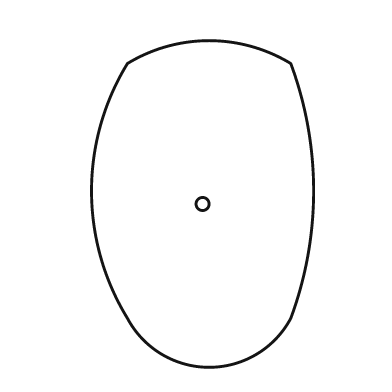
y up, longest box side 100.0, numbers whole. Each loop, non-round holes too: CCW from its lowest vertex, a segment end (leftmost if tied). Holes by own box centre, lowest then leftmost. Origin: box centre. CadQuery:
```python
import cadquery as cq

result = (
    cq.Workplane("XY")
    .moveTo(-23.0, -35.0)
    .threePointArc((2.0, -50.0), (27.0, -35.0))
    .threePointArc((34.0, 4.0), (27.0, 43.0))
    .threePointArc((2.0, 50.0), (-23.0, 43.0))
    .threePointArc((-34.0, 4.0), (-23.0, -35.0))
    .close()
    .moveTo(0.0, 0.0)
    .circle(2.0)
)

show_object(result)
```